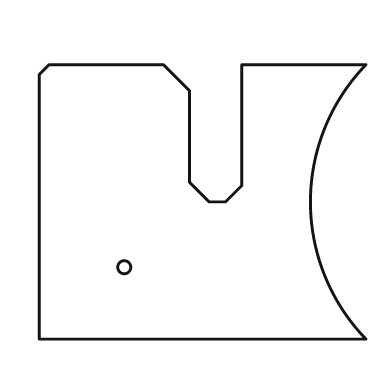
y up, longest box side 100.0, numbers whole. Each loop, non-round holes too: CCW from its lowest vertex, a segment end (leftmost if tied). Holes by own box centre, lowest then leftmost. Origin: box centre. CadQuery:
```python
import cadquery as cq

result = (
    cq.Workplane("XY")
    .moveTo(-50.0, -42.0)
    .lineTo(50.0, -42.0)
    .threePointArc((33.0, 0.0), (50.0, 42.0))
    .lineTo(12.0, 42.0)
    .lineTo(12.0, 5.0)
    .lineTo(7.0, 0.0)
    .lineTo(2.0, 0.0)
    .lineTo(-4.0, 6.0)
    .lineTo(-4.0, 34.0)
    .lineTo(-12.0, 42.0)
    .lineTo(-47.0, 42.0)
    .lineTo(-50.0, 39.0)
    .close()
    .moveTo(-24.0, -20.0)
    .circle(2.0)
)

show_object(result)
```